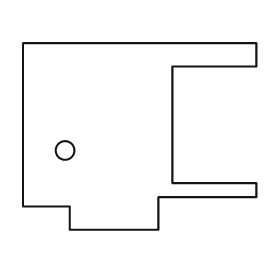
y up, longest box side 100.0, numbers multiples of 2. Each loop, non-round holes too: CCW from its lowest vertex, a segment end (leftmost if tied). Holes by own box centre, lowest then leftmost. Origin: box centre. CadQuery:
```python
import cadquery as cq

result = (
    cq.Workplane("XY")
    .moveTo(-30.0, -40.0)
    .lineTo(8.0, -40.0)
    .lineTo(8.0, -26.0)
    .lineTo(50.0, -26.0)
    .lineTo(50.0, -20.0)
    .lineTo(14.0, -20.0)
    .lineTo(14.0, 30.0)
    .lineTo(50.0, 30.0)
    .lineTo(50.0, 40.0)
    .lineTo(-50.0, 40.0)
    .lineTo(-50.0, -30.0)
    .lineTo(-30.0, -30.0)
    .close()
    .moveTo(-32.0, -6.0)
    .circle(4.0)
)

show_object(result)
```